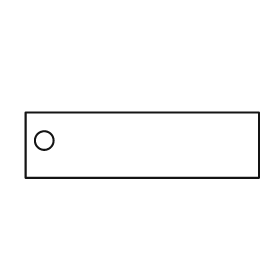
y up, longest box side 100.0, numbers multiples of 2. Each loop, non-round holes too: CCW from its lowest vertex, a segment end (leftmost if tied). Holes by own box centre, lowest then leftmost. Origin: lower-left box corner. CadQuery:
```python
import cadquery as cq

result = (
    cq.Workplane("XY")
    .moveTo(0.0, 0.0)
    .lineTo(100.0, 0.0)
    .lineTo(100.0, 28.0)
    .lineTo(0.0, 28.0)
    .close()
    .moveTo(8.0, 16.0)
    .circle(4.0)
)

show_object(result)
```